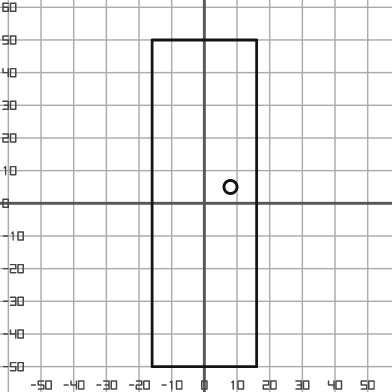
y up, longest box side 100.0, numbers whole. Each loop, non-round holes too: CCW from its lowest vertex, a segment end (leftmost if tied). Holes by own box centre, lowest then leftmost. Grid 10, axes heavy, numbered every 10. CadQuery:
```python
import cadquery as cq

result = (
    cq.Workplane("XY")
    .moveTo(-16.0, -50.0)
    .lineTo(16.0, -50.0)
    .lineTo(16.0, 50.0)
    .lineTo(-16.0, 50.0)
    .close()
    .moveTo(8.0, 5.0)
    .circle(2.0)
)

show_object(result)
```